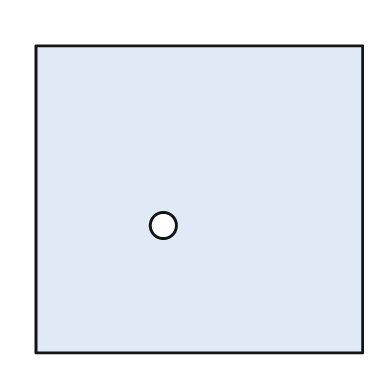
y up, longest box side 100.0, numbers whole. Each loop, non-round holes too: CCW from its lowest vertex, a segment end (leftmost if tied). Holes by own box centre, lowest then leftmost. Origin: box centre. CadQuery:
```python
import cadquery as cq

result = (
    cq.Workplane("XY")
    .moveTo(-50.0, -47.0)
    .lineTo(50.0, -47.0)
    .lineTo(50.0, 47.0)
    .lineTo(-50.0, 47.0)
    .close()
    .moveTo(-11.0, -8.0)
    .circle(4.0)
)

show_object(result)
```